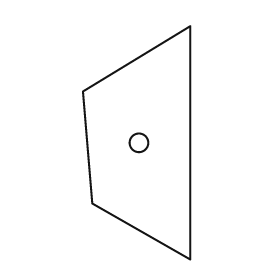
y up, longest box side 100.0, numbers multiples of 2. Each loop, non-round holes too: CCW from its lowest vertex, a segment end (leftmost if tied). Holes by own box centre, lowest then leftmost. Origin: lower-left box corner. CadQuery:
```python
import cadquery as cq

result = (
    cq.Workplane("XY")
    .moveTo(46.0, 0.0)
    .lineTo(46.0, 100.0)
    .lineTo(0.0, 72.0)
    .lineTo(4.0, 24.0)
    .close()
    .moveTo(24.0, 50.0)
    .circle(4.0)
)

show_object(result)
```